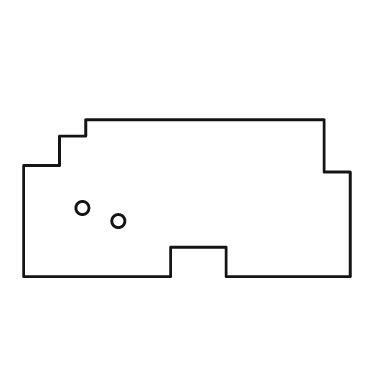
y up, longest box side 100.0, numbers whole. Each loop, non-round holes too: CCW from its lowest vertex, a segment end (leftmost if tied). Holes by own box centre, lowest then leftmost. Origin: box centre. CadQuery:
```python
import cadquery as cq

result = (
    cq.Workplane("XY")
    .moveTo(-50.0, -24.0)
    .lineTo(-5.0, -24.0)
    .lineTo(-5.0, -15.0)
    .lineTo(12.0, -15.0)
    .lineTo(12.0, -24.0)
    .lineTo(50.0, -24.0)
    .lineTo(50.0, 8.0)
    .lineTo(42.0, 8.0)
    .lineTo(42.0, 24.0)
    .lineTo(-31.0, 24.0)
    .lineTo(-31.0, 19.0)
    .lineTo(-39.0, 19.0)
    .lineTo(-39.0, 10.0)
    .lineTo(-50.0, 10.0)
    .close()
    .moveTo(-21.0, -7.0)
    .circle(2.0)
    .moveTo(-32.0, -3.0)
    .circle(2.0)
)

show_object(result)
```